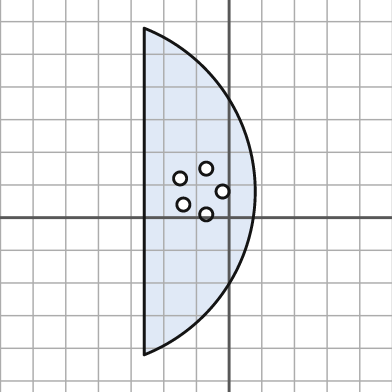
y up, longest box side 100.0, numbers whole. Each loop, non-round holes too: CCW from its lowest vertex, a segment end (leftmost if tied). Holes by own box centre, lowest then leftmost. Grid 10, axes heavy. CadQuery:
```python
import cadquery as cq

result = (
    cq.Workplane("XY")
    .moveTo(-26.0, -42.0)
    .threePointArc((8.0, 8.0), (-26.0, 58.0))
    .close()
    .moveTo(-7.0, 1.0)
    .circle(2.0)
    .moveTo(-14.0, 4.0)
    .circle(2.0)
    .moveTo(-2.0, 8.0)
    .circle(2.0)
    .moveTo(-15.0, 12.0)
    .circle(2.0)
    .moveTo(-7.0, 15.0)
    .circle(2.0)
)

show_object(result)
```